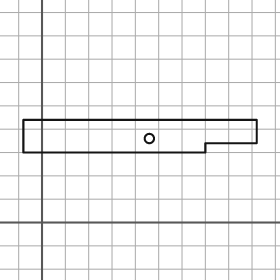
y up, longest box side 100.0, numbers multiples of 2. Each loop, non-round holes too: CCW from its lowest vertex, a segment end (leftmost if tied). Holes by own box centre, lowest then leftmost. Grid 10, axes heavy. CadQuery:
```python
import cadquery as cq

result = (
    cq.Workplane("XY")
    .moveTo(-8.0, 30.0)
    .lineTo(70.0, 30.0)
    .lineTo(70.0, 34.0)
    .lineTo(92.0, 34.0)
    .lineTo(92.0, 44.0)
    .lineTo(-8.0, 44.0)
    .close()
    .moveTo(46.0, 36.0)
    .circle(2.0)
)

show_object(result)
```